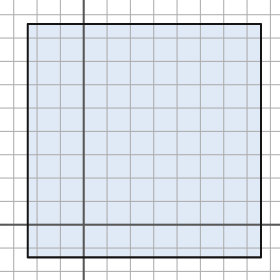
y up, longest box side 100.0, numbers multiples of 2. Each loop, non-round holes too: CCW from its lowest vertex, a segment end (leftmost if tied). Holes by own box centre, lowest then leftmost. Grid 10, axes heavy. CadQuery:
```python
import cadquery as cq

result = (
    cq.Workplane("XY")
    .moveTo(-24.0, -14.0)
    .lineTo(76.0, -14.0)
    .lineTo(76.0, 86.0)
    .lineTo(-24.0, 86.0)
    .close()
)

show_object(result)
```